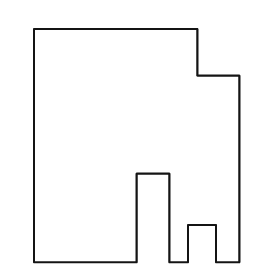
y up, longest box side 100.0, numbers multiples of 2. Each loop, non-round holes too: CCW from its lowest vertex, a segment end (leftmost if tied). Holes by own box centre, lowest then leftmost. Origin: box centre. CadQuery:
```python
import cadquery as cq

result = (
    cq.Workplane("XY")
    .moveTo(-44.0, -50.0)
    .lineTo(0.0, -50.0)
    .lineTo(0.0, -12.0)
    .lineTo(14.0, -12.0)
    .lineTo(14.0, -50.0)
    .lineTo(22.0, -50.0)
    .lineTo(22.0, -34.0)
    .lineTo(34.0, -34.0)
    .lineTo(34.0, -50.0)
    .lineTo(44.0, -50.0)
    .lineTo(44.0, 30.0)
    .lineTo(26.0, 30.0)
    .lineTo(26.0, 50.0)
    .lineTo(-44.0, 50.0)
    .close()
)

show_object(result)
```